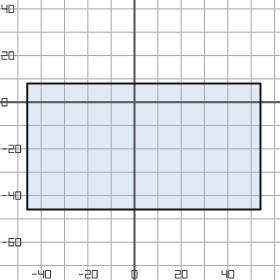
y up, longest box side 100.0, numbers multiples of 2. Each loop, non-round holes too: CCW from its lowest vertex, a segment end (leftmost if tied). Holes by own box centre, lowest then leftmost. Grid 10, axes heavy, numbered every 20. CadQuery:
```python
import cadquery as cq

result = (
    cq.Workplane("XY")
    .moveTo(-46.0, -46.0)
    .lineTo(54.0, -46.0)
    .lineTo(54.0, 8.0)
    .lineTo(-46.0, 8.0)
    .close()
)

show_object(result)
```